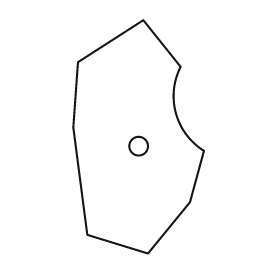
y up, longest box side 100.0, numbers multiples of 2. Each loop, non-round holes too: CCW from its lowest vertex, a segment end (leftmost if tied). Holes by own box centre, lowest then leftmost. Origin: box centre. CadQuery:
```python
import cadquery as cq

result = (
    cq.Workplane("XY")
    .moveTo(4.0, -50.0)
    .lineTo(22.0, -28.0)
    .lineTo(28.0, -6.0)
    .threePointArc((16.0, 10.0), (18.0, 30.0))
    .lineTo(2.0, 50.0)
    .lineTo(-26.0, 32.0)
    .lineTo(-28.0, 4.0)
    .lineTo(-22.0, -42.0)
    .close()
    .moveTo(0.0, -4.0)
    .circle(4.0)
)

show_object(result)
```